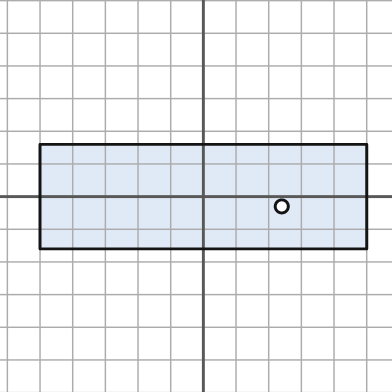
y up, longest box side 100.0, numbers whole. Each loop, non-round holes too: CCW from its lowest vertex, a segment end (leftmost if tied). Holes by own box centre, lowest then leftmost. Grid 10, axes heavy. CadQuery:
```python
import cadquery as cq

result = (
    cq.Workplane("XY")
    .moveTo(-50.0, -16.0)
    .lineTo(50.0, -16.0)
    .lineTo(50.0, 16.0)
    .lineTo(-50.0, 16.0)
    .close()
    .moveTo(24.0, -3.0)
    .circle(2.0)
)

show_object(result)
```